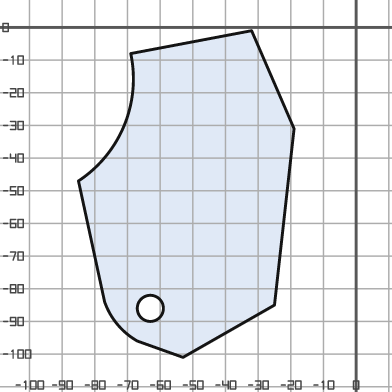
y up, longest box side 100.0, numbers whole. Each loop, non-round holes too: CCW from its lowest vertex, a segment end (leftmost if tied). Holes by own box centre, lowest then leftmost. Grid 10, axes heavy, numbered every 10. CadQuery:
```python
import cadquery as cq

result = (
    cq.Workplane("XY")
    .moveTo(-53.0, -101.0)
    .lineTo(-25.0, -85.0)
    .lineTo(-19.0, -31.0)
    .lineTo(-32.0, -1.0)
    .lineTo(-69.0, -8.0)
    .threePointArc((-71.0, -30.0), (-85.0, -47.0))
    .lineTo(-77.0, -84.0)
    .threePointArc((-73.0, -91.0), (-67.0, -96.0))
    .close()
    .moveTo(-63.0, -86.0)
    .circle(4.0)
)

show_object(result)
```